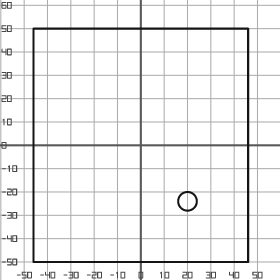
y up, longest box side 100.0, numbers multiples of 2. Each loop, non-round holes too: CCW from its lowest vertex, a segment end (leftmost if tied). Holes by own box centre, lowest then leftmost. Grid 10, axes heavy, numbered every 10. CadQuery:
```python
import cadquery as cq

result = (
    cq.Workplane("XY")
    .moveTo(-46.0, -50.0)
    .lineTo(46.0, -50.0)
    .lineTo(46.0, 50.0)
    .lineTo(-46.0, 50.0)
    .close()
    .moveTo(20.0, -24.0)
    .circle(4.0)
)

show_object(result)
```